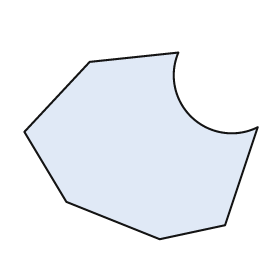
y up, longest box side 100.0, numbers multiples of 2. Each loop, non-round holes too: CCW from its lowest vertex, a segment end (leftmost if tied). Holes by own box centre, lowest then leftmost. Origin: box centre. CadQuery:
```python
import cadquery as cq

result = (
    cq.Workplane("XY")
    .moveTo(8.0, -40.0)
    .lineTo(36.0, -34.0)
    .lineTo(50.0, 8.0)
    .threePointArc((22.0, 12.0), (16.0, 40.0))
    .lineTo(-22.0, 36.0)
    .lineTo(-50.0, 6.0)
    .lineTo(-32.0, -24.0)
    .close()
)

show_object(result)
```